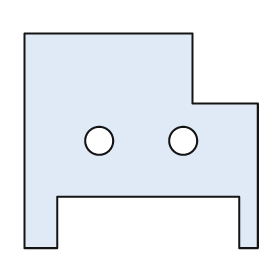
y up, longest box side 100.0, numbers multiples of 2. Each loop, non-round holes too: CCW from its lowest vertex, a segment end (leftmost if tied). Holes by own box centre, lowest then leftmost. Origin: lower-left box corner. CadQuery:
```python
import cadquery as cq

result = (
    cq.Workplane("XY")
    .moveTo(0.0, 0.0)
    .lineTo(14.0, 0.0)
    .lineTo(14.0, 22.0)
    .lineTo(92.0, 22.0)
    .lineTo(92.0, 0.0)
    .lineTo(100.0, 0.0)
    .lineTo(100.0, 62.0)
    .lineTo(72.0, 62.0)
    .lineTo(72.0, 92.0)
    .lineTo(0.0, 92.0)
    .close()
    .moveTo(32.0, 46.0)
    .circle(6.0)
    .moveTo(68.0, 46.0)
    .circle(6.0)
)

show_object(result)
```